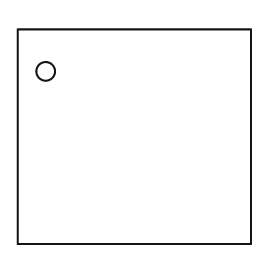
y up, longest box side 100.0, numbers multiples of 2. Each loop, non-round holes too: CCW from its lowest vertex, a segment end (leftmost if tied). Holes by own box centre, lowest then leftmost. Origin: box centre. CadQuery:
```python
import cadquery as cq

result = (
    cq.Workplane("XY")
    .moveTo(-50.0, -46.0)
    .lineTo(50.0, -46.0)
    .lineTo(50.0, 46.0)
    .lineTo(-50.0, 46.0)
    .close()
    .moveTo(-38.0, 28.0)
    .circle(4.0)
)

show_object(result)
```